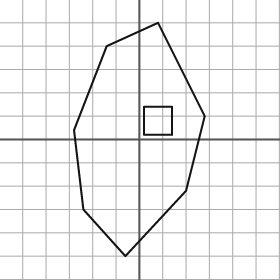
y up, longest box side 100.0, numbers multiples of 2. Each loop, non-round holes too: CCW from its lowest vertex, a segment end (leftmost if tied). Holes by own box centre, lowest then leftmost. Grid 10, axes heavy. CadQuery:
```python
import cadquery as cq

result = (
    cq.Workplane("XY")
    .moveTo(-6.0, -50.0)
    .lineTo(20.0, -22.0)
    .lineTo(28.0, 10.0)
    .lineTo(8.0, 50.0)
    .lineTo(-14.0, 40.0)
    .lineTo(-28.0, 4.0)
    .lineTo(-24.0, -30.0)
    .close()
    .moveTo(2.0, 2.0)
    .lineTo(14.0, 2.0)
    .lineTo(14.0, 14.0)
    .lineTo(2.0, 14.0)
    .close()
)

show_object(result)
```